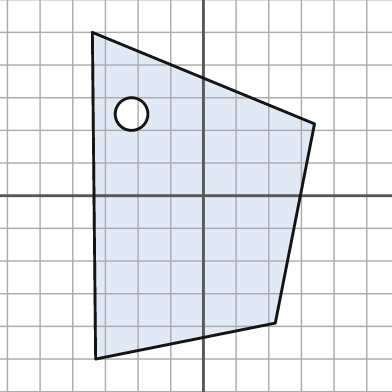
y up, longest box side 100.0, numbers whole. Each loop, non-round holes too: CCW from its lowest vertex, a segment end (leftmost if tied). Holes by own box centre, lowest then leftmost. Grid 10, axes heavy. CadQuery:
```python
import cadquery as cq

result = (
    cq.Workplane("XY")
    .moveTo(-33.0, -50.0)
    .lineTo(22.0, -39.0)
    .lineTo(34.0, 22.0)
    .lineTo(-34.0, 50.0)
    .close()
    .moveTo(-22.0, 25.0)
    .circle(5.0)
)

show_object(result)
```